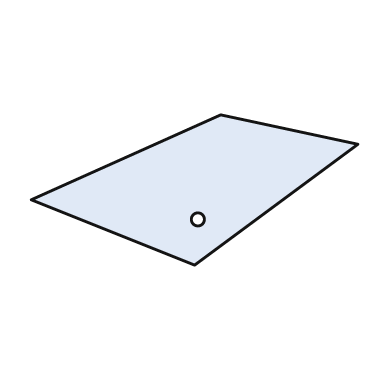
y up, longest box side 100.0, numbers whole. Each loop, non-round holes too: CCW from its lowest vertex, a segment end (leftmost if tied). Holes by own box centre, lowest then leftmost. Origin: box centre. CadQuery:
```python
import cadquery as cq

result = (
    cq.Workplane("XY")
    .moveTo(0.0, -23.0)
    .lineTo(50.0, 14.0)
    .lineTo(8.0, 23.0)
    .lineTo(-50.0, -3.0)
    .close()
    .moveTo(1.0, -9.0)
    .circle(2.0)
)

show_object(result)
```